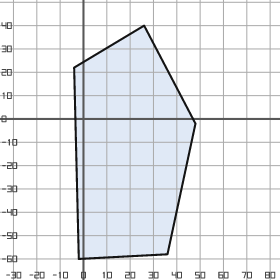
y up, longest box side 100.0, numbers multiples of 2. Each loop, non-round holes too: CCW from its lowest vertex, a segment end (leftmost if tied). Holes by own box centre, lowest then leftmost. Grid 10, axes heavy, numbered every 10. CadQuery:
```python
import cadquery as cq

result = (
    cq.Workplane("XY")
    .moveTo(-2.0, -60.0)
    .lineTo(36.0, -58.0)
    .lineTo(48.0, -2.0)
    .lineTo(26.0, 40.0)
    .lineTo(-4.0, 22.0)
    .close()
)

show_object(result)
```